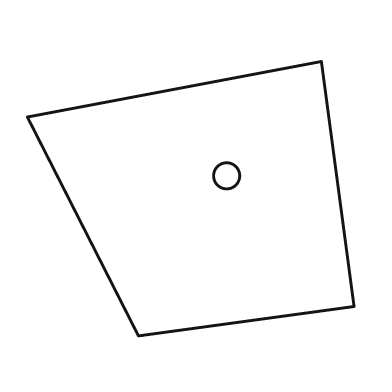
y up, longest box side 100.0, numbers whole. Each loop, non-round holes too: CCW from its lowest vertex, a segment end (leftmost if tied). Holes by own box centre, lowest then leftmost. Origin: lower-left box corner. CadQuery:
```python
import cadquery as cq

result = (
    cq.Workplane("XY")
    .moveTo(34.0, 0.0)
    .lineTo(100.0, 9.0)
    .lineTo(90.0, 84.0)
    .lineTo(0.0, 67.0)
    .close()
    .moveTo(61.0, 49.0)
    .circle(4.0)
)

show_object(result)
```